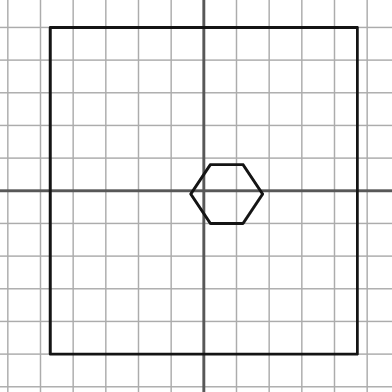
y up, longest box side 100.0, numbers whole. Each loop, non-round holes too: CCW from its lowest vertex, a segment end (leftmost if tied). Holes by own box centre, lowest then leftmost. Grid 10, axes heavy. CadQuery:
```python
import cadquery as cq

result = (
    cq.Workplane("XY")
    .moveTo(-47.0, -50.0)
    .lineTo(47.0, -50.0)
    .lineTo(47.0, 50.0)
    .lineTo(-47.0, 50.0)
    .close()
    .moveTo(2.0, -10.0)
    .lineTo(12.0, -10.0)
    .lineTo(18.0, -1.0)
    .lineTo(12.0, 8.0)
    .lineTo(2.0, 8.0)
    .lineTo(-4.0, -1.0)
    .close()
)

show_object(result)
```